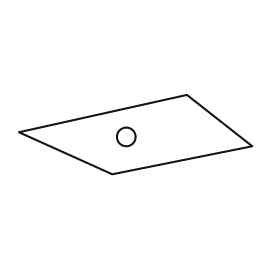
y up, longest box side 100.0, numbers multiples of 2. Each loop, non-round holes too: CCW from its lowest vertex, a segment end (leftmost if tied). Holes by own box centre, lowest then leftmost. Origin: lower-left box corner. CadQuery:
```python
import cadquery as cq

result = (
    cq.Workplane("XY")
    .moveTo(40.0, 0.0)
    .lineTo(100.0, 12.0)
    .lineTo(72.0, 34.0)
    .lineTo(0.0, 18.0)
    .close()
    .moveTo(46.0, 16.0)
    .circle(4.0)
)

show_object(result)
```